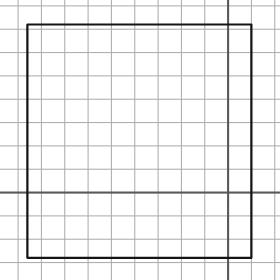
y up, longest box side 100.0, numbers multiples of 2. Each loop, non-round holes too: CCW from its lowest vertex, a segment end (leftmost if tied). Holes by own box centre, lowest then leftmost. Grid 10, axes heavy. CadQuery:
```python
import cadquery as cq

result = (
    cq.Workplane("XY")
    .moveTo(-86.0, -28.0)
    .lineTo(10.0, -28.0)
    .lineTo(10.0, 72.0)
    .lineTo(-86.0, 72.0)
    .close()
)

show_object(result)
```